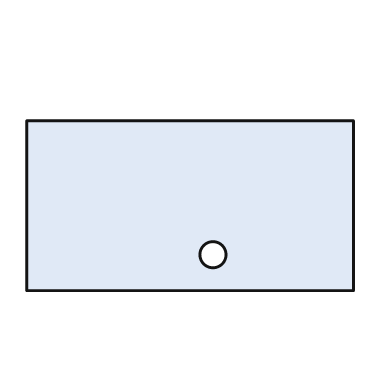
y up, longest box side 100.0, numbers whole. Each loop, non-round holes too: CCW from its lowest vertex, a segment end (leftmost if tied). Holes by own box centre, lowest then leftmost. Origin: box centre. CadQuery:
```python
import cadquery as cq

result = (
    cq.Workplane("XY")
    .moveTo(-50.0, -26.0)
    .lineTo(50.0, -26.0)
    .lineTo(50.0, 26.0)
    .lineTo(-50.0, 26.0)
    .close()
    .moveTo(7.0, -15.0)
    .circle(4.0)
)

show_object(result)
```